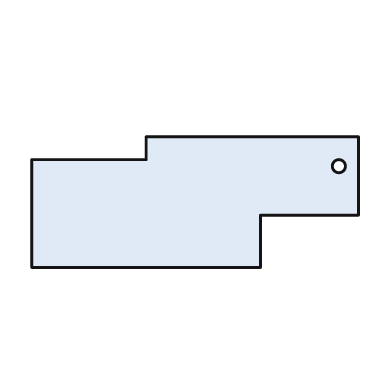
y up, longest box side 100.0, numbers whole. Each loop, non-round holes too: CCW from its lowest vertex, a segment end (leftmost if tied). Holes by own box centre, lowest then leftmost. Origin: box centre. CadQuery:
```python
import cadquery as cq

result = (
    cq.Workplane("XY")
    .moveTo(-50.0, -20.0)
    .lineTo(20.0, -20.0)
    .lineTo(20.0, -4.0)
    .lineTo(50.0, -4.0)
    .lineTo(50.0, 20.0)
    .lineTo(-15.0, 20.0)
    .lineTo(-15.0, 13.0)
    .lineTo(-50.0, 13.0)
    .close()
    .moveTo(44.0, 11.0)
    .circle(2.0)
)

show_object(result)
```